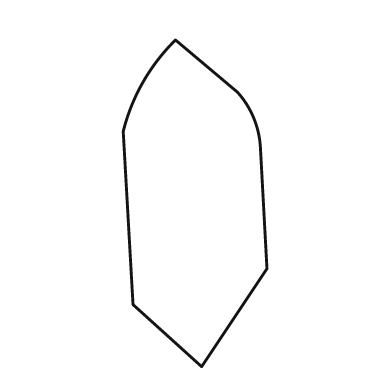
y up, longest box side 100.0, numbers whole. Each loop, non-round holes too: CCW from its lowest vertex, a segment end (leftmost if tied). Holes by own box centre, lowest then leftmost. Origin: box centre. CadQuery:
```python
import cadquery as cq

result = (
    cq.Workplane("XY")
    .moveTo(2.0, -50.0)
    .lineTo(22.0, -20.0)
    .lineTo(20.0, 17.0)
    .threePointArc((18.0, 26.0), (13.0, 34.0))
    .lineTo(-6.0, 50.0)
    .threePointArc((-16.0, 37.0), (-22.0, 22.0))
    .lineTo(-19.0, -31.0)
    .close()
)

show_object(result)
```